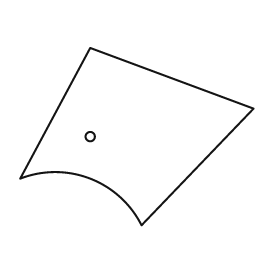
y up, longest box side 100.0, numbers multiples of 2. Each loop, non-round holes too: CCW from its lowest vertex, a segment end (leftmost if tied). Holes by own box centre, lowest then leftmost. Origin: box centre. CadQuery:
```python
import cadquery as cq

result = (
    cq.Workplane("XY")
    .moveTo(2.0, -38.0)
    .lineTo(50.0, 12.0)
    .lineTo(-20.0, 38.0)
    .lineTo(-50.0, -18.0)
    .threePointArc((-20.0, -18.0), (2.0, -38.0))
    .close()
    .moveTo(-20.0, 0.0)
    .circle(2.0)
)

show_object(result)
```